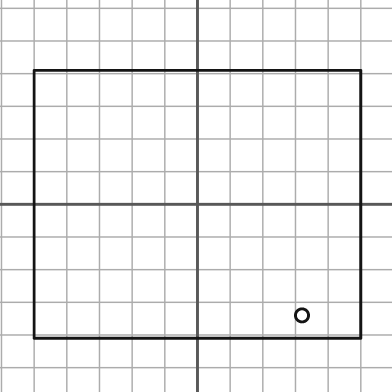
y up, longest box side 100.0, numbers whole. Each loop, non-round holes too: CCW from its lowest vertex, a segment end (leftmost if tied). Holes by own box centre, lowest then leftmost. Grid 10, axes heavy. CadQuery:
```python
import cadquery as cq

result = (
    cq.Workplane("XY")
    .moveTo(-50.0, -41.0)
    .lineTo(50.0, -41.0)
    .lineTo(50.0, 41.0)
    .lineTo(-50.0, 41.0)
    .close()
    .moveTo(32.0, -34.0)
    .circle(2.0)
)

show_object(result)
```